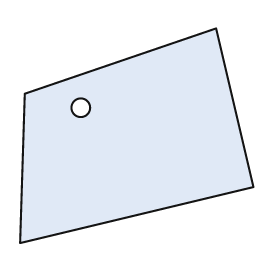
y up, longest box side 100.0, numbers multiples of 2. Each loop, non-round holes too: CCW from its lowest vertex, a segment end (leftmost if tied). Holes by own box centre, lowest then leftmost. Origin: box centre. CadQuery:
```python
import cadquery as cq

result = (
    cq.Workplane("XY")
    .moveTo(-50.0, -46.0)
    .lineTo(50.0, -22.0)
    .lineTo(34.0, 46.0)
    .lineTo(-48.0, 18.0)
    .close()
    .moveTo(-24.0, 12.0)
    .circle(4.0)
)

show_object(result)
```